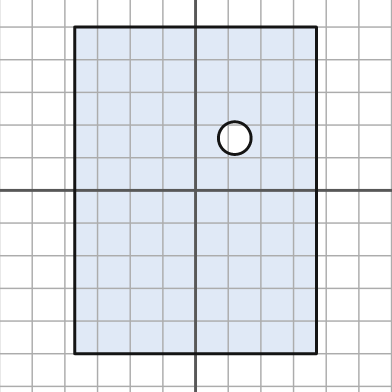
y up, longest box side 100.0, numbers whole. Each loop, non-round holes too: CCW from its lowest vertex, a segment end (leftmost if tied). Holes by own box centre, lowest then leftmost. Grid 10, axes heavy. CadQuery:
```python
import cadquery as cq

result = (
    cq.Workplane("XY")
    .moveTo(-37.0, -50.0)
    .lineTo(37.0, -50.0)
    .lineTo(37.0, 50.0)
    .lineTo(-37.0, 50.0)
    .close()
    .moveTo(12.0, 16.0)
    .circle(5.0)
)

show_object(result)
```